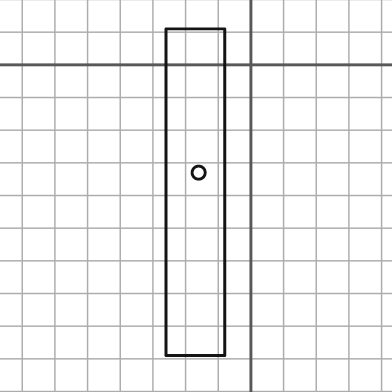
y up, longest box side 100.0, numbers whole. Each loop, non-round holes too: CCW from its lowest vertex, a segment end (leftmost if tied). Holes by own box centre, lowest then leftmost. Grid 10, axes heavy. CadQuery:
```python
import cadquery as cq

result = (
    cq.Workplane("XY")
    .moveTo(-26.0, -89.0)
    .lineTo(-8.0, -89.0)
    .lineTo(-8.0, 11.0)
    .lineTo(-26.0, 11.0)
    .close()
    .moveTo(-16.0, -33.0)
    .circle(2.0)
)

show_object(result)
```